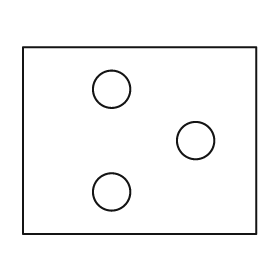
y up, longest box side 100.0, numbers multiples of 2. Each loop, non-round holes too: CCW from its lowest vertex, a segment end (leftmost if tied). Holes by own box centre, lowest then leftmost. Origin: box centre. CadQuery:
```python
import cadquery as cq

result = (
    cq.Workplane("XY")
    .moveTo(-50.0, -40.0)
    .lineTo(50.0, -40.0)
    .lineTo(50.0, 40.0)
    .lineTo(-50.0, 40.0)
    .close()
    .moveTo(-12.0, -22.0)
    .circle(8.0)
    .moveTo(24.0, 0.0)
    .circle(8.0)
    .moveTo(-12.0, 22.0)
    .circle(8.0)
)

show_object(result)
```